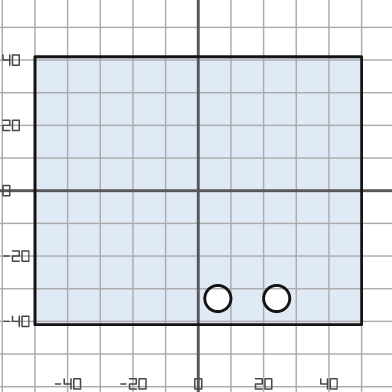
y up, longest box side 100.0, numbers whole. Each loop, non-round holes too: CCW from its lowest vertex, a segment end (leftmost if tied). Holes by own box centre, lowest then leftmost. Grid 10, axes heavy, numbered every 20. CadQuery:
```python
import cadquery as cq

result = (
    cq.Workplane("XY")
    .moveTo(-50.0, -41.0)
    .lineTo(50.0, -41.0)
    .lineTo(50.0, 41.0)
    .lineTo(-50.0, 41.0)
    .close()
    .moveTo(6.0, -33.0)
    .circle(4.0)
    .moveTo(24.0, -33.0)
    .circle(4.0)
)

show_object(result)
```